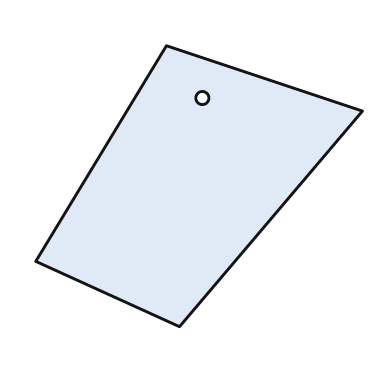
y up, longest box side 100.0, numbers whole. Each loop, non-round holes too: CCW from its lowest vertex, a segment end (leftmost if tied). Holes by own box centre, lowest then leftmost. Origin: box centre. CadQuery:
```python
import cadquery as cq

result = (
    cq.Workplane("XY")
    .moveTo(-6.0, -43.0)
    .lineTo(50.0, 23.0)
    .lineTo(-10.0, 43.0)
    .lineTo(-50.0, -23.0)
    .close()
    .moveTo(1.0, 27.0)
    .circle(2.0)
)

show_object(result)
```